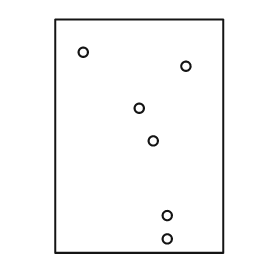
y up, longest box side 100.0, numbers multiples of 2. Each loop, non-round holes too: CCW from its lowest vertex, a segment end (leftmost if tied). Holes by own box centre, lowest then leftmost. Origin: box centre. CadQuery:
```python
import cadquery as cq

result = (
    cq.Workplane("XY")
    .moveTo(-36.0, -50.0)
    .lineTo(36.0, -50.0)
    .lineTo(36.0, 50.0)
    .lineTo(-36.0, 50.0)
    .close()
    .moveTo(12.0, -44.0)
    .circle(2.0)
    .moveTo(12.0, -34.0)
    .circle(2.0)
    .moveTo(6.0, -2.0)
    .circle(2.0)
    .moveTo(0.0, 12.0)
    .circle(2.0)
    .moveTo(20.0, 30.0)
    .circle(2.0)
    .moveTo(-24.0, 36.0)
    .circle(2.0)
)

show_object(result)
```